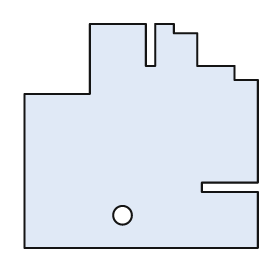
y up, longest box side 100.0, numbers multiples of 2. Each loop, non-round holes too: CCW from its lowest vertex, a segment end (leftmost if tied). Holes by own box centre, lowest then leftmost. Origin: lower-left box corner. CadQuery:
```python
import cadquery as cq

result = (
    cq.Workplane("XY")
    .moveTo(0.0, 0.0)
    .lineTo(100.0, 0.0)
    .lineTo(100.0, 24.0)
    .lineTo(76.0, 24.0)
    .lineTo(76.0, 28.0)
    .lineTo(100.0, 28.0)
    .lineTo(100.0, 72.0)
    .lineTo(90.0, 72.0)
    .lineTo(90.0, 78.0)
    .lineTo(74.0, 78.0)
    .lineTo(74.0, 92.0)
    .lineTo(64.0, 92.0)
    .lineTo(64.0, 96.0)
    .lineTo(56.0, 96.0)
    .lineTo(56.0, 78.0)
    .lineTo(52.0, 78.0)
    .lineTo(52.0, 96.0)
    .lineTo(28.0, 96.0)
    .lineTo(28.0, 66.0)
    .lineTo(0.0, 66.0)
    .close()
    .moveTo(42.0, 14.0)
    .circle(4.0)
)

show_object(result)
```